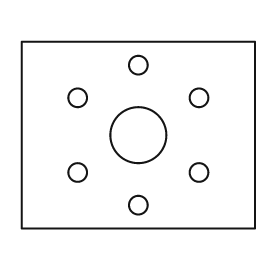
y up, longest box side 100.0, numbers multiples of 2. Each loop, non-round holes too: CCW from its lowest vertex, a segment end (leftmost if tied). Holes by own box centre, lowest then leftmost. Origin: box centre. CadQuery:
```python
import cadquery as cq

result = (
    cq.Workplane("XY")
    .moveTo(-50.0, -40.0)
    .lineTo(50.0, -40.0)
    .lineTo(50.0, 40.0)
    .lineTo(-50.0, 40.0)
    .close()
    .moveTo(0.0, -30.0)
    .circle(4.0)
    .moveTo(-26.0, -16.0)
    .circle(4.0)
    .moveTo(26.0, -16.0)
    .circle(4.0)
    .moveTo(0.0, 0.0)
    .circle(12.0)
    .moveTo(-26.0, 16.0)
    .circle(4.0)
    .moveTo(26.0, 16.0)
    .circle(4.0)
    .moveTo(0.0, 30.0)
    .circle(4.0)
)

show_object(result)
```